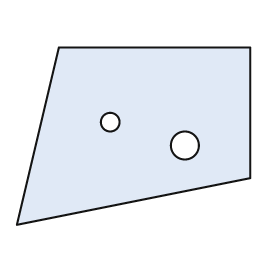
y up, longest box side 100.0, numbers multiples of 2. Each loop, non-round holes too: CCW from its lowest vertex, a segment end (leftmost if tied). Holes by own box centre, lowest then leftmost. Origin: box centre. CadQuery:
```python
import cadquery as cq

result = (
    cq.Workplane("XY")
    .moveTo(-50.0, -38.0)
    .lineTo(50.0, -18.0)
    .lineTo(50.0, 38.0)
    .lineTo(-32.0, 38.0)
    .close()
    .moveTo(22.0, -4.0)
    .circle(6.0)
    .moveTo(-10.0, 6.0)
    .circle(4.0)
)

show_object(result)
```